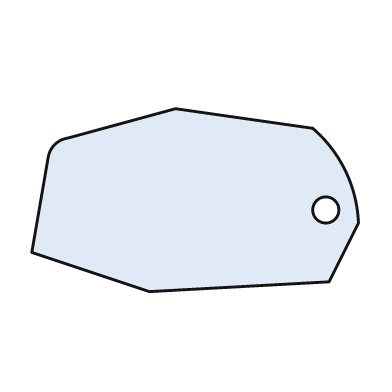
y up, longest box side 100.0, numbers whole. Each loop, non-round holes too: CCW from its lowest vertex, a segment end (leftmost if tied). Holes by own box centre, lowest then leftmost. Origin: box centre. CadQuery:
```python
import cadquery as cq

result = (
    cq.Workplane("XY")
    .moveTo(-14.0, -28.0)
    .lineTo(41.0, -25.0)
    .lineTo(50.0, -7.0)
    .threePointArc((46.0, 9.0), (36.0, 22.0))
    .lineTo(-6.0, 28.0)
    .lineTo(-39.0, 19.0)
    .threePointArc((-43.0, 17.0), (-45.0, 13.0))
    .lineTo(-50.0, -16.0)
    .close()
    .moveTo(40.0, -3.0)
    .circle(4.0)
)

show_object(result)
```